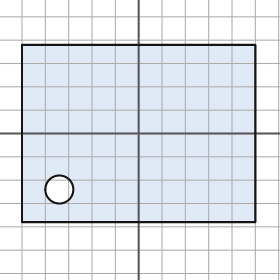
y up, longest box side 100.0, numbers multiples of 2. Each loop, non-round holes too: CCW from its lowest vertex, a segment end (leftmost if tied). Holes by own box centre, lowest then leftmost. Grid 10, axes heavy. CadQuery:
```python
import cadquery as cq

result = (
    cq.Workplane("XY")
    .moveTo(-50.0, -38.0)
    .lineTo(50.0, -38.0)
    .lineTo(50.0, 38.0)
    .lineTo(-50.0, 38.0)
    .close()
    .moveTo(-34.0, -24.0)
    .circle(6.0)
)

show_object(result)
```